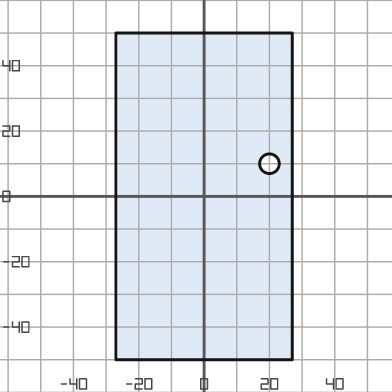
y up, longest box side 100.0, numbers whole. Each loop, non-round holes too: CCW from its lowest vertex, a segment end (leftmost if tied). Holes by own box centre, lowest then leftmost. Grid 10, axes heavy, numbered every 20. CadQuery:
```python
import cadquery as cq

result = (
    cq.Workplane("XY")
    .moveTo(-27.0, -50.0)
    .lineTo(27.0, -50.0)
    .lineTo(27.0, 50.0)
    .lineTo(-27.0, 50.0)
    .close()
    .moveTo(20.0, 10.0)
    .circle(3.0)
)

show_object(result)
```